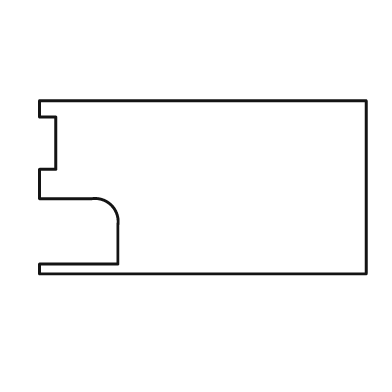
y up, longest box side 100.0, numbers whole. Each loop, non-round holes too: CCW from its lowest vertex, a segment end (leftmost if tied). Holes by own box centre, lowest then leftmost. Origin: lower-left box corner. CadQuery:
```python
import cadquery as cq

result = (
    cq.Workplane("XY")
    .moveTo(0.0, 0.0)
    .lineTo(100.0, 0.0)
    .lineTo(100.0, 53.0)
    .lineTo(0.0, 53.0)
    .lineTo(0.0, 48.0)
    .lineTo(5.0, 48.0)
    .lineTo(5.0, 32.0)
    .lineTo(0.0, 32.0)
    .lineTo(0.0, 23.0)
    .lineTo(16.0, 23.0)
    .threePointArc((22.0, 21.0), (24.0, 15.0))
    .lineTo(24.0, 3.0)
    .lineTo(0.0, 3.0)
    .close()
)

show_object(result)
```